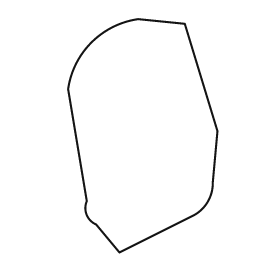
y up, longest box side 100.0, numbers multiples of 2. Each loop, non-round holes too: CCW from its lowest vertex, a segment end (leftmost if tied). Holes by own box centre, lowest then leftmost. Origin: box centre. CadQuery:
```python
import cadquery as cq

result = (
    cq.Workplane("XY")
    .moveTo(-10.0, -50.0)
    .lineTo(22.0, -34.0)
    .threePointArc((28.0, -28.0), (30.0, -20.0))
    .lineTo(32.0, 2.0)
    .lineTo(18.0, 48.0)
    .lineTo(-2.0, 50.0)
    .threePointArc((-22.0, 40.0), (-32.0, 20.0))
    .lineTo(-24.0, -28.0)
    .threePointArc((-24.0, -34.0), (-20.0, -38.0))
    .close()
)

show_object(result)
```